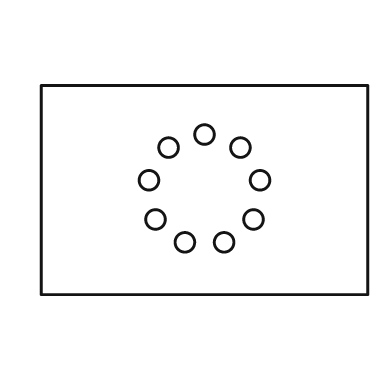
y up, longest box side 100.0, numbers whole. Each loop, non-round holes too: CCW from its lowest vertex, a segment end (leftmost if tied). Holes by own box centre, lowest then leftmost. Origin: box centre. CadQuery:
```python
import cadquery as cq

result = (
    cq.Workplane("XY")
    .moveTo(-50.0, -32.0)
    .lineTo(50.0, -32.0)
    .lineTo(50.0, 32.0)
    .lineTo(-50.0, 32.0)
    .close()
    .moveTo(-6.0, -16.0)
    .circle(3.0)
    .moveTo(6.0, -16.0)
    .circle(3.0)
    .moveTo(-15.0, -9.0)
    .circle(3.0)
    .moveTo(15.0, -9.0)
    .circle(3.0)
    .moveTo(-17.0, 3.0)
    .circle(3.0)
    .moveTo(17.0, 3.0)
    .circle(3.0)
    .moveTo(-11.0, 13.0)
    .circle(3.0)
    .moveTo(11.0, 13.0)
    .circle(3.0)
    .moveTo(0.0, 17.0)
    .circle(3.0)
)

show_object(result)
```